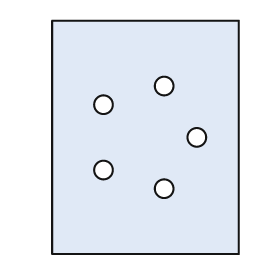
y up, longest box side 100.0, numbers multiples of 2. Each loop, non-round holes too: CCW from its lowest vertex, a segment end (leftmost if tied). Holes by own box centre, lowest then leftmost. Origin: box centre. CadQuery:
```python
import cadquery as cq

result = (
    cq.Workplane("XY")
    .moveTo(-40.0, -50.0)
    .lineTo(40.0, -50.0)
    .lineTo(40.0, 50.0)
    .lineTo(-40.0, 50.0)
    .close()
    .moveTo(8.0, -22.0)
    .circle(4.0)
    .moveTo(-18.0, -14.0)
    .circle(4.0)
    .moveTo(22.0, 0.0)
    .circle(4.0)
    .moveTo(-18.0, 14.0)
    .circle(4.0)
    .moveTo(8.0, 22.0)
    .circle(4.0)
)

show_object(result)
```